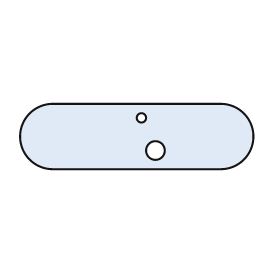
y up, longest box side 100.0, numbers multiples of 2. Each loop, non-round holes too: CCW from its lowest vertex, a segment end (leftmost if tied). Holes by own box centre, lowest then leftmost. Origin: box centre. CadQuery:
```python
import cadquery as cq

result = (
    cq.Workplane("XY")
    .moveTo(-36.0, -14.0)
    .lineTo(36.0, -14.0)
    .threePointArc((50.0, 0.0), (36.0, 14.0))
    .lineTo(-36.0, 14.0)
    .threePointArc((-50.0, 0.0), (-36.0, -14.0))
    .close()
    .moveTo(8.0, -6.0)
    .circle(4.0)
    .moveTo(2.0, 8.0)
    .circle(2.0)
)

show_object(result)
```